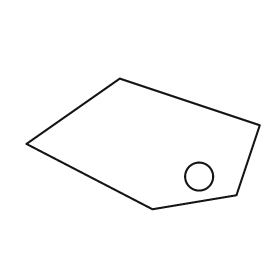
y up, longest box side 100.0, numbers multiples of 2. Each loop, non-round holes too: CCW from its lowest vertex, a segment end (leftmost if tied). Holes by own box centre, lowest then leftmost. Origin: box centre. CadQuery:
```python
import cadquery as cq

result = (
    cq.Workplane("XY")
    .moveTo(4.0, -28.0)
    .lineTo(40.0, -22.0)
    .lineTo(50.0, 8.0)
    .lineTo(-10.0, 28.0)
    .lineTo(-50.0, 0.0)
    .close()
    .moveTo(24.0, -14.0)
    .circle(6.0)
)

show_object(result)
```